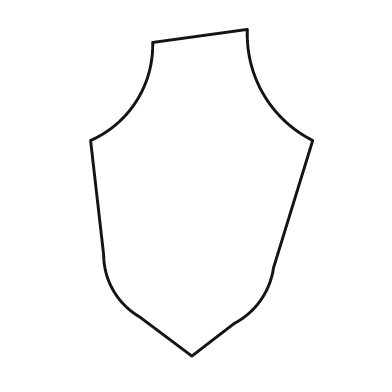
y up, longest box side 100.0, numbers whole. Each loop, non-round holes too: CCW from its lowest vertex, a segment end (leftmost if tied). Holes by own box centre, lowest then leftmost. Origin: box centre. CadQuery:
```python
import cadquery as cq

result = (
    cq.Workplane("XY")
    .moveTo(-3.0, -50.0)
    .lineTo(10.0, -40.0)
    .threePointArc((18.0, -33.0), (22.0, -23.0))
    .lineTo(34.0, 16.0)
    .threePointArc((19.0, 30.0), (14.0, 50.0))
    .lineTo(-15.0, 46.0)
    .threePointArc((-20.0, 28.0), (-34.0, 16.0))
    .lineTo(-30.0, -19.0)
    .threePointArc((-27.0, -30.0), (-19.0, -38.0))
    .close()
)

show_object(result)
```